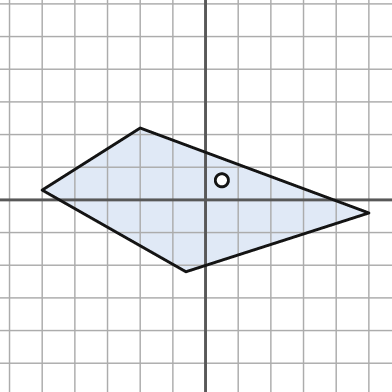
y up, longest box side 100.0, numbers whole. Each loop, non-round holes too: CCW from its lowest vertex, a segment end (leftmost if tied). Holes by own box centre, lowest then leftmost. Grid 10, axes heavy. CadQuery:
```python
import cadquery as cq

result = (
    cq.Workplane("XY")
    .moveTo(-6.0, -22.0)
    .lineTo(50.0, -4.0)
    .lineTo(-20.0, 22.0)
    .lineTo(-50.0, 3.0)
    .close()
    .moveTo(5.0, 6.0)
    .circle(2.0)
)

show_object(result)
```